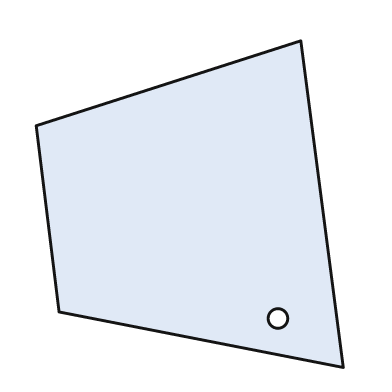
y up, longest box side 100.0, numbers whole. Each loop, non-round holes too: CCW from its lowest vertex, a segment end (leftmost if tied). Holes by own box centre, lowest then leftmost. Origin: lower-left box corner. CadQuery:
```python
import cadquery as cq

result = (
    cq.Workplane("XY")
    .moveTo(94.0, 0.0)
    .lineTo(81.0, 100.0)
    .lineTo(0.0, 74.0)
    .lineTo(7.0, 17.0)
    .close()
    .moveTo(74.0, 15.0)
    .circle(3.0)
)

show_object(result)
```